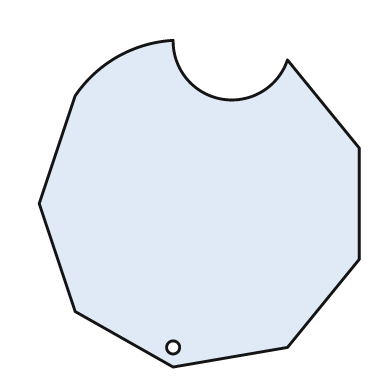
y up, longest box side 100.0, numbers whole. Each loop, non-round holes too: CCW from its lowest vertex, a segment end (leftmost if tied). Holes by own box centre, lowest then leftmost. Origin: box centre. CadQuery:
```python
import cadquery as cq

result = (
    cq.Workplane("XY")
    .moveTo(-8.0, -50.0)
    .lineTo(27.0, -44.0)
    .lineTo(49.0, -17.0)
    .lineTo(49.0, 17.0)
    .lineTo(27.0, 44.0)
    .threePointArc((7.0, 32.0), (-8.0, 50.0))
    .threePointArc((-25.0, 45.0), (-38.0, 33.0))
    .lineTo(-49.0, 0.0)
    .lineTo(-38.0, -33.0)
    .close()
    .moveTo(-8.0, -44.0)
    .circle(2.0)
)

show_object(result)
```